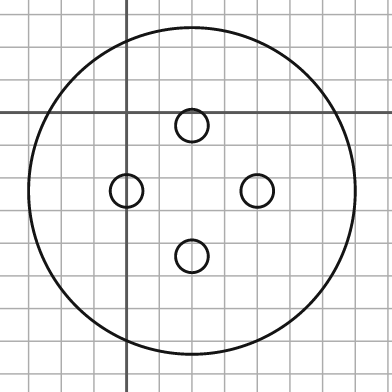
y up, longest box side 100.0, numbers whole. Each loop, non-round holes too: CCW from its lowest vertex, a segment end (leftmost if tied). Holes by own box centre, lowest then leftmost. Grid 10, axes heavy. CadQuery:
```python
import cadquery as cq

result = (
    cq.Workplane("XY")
    .moveTo(20.0, -24.0)
    .circle(50.0)
    .moveTo(20.0, -44.0)
    .circle(5.0)
    .moveTo(0.0, -24.0)
    .circle(5.0)
    .moveTo(40.0, -24.0)
    .circle(5.0)
    .moveTo(20.0, -4.0)
    .circle(5.0)
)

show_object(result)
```